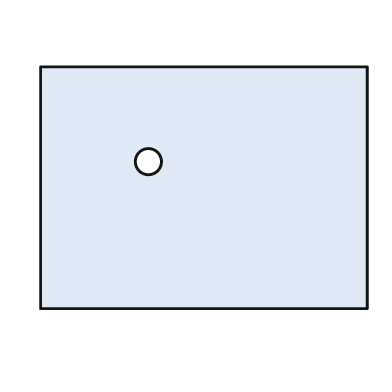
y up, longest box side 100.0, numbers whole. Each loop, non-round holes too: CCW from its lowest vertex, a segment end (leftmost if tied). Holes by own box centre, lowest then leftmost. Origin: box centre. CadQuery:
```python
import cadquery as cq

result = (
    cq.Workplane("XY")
    .moveTo(-50.0, -37.0)
    .lineTo(50.0, -37.0)
    .lineTo(50.0, 37.0)
    .lineTo(-50.0, 37.0)
    .close()
    .moveTo(-17.0, 8.0)
    .circle(4.0)
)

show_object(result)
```